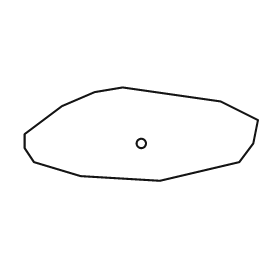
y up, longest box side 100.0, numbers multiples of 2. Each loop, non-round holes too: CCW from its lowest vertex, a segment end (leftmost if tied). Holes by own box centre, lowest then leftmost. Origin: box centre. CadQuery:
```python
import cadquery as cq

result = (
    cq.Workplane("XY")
    .moveTo(8.0, -20.0)
    .lineTo(42.0, -12.0)
    .lineTo(48.0, -4.0)
    .lineTo(50.0, 6.0)
    .lineTo(34.0, 14.0)
    .lineTo(-8.0, 20.0)
    .lineTo(-20.0, 18.0)
    .lineTo(-34.0, 12.0)
    .lineTo(-50.0, 0.0)
    .lineTo(-50.0, -6.0)
    .lineTo(-46.0, -12.0)
    .lineTo(-26.0, -18.0)
    .close()
    .moveTo(0.0, -4.0)
    .circle(2.0)
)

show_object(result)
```